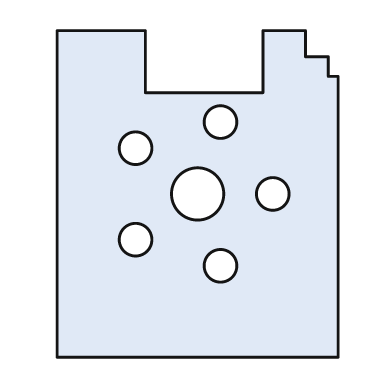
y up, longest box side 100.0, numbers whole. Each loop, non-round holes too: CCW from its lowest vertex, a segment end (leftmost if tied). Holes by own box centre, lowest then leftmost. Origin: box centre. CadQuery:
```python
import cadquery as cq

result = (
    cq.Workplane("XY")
    .moveTo(-43.0, -50.0)
    .lineTo(43.0, -50.0)
    .lineTo(43.0, 36.0)
    .lineTo(40.0, 36.0)
    .lineTo(40.0, 42.0)
    .lineTo(33.0, 42.0)
    .lineTo(33.0, 50.0)
    .lineTo(20.0, 50.0)
    .lineTo(20.0, 31.0)
    .lineTo(-16.0, 31.0)
    .lineTo(-16.0, 50.0)
    .lineTo(-43.0, 50.0)
    .close()
    .moveTo(7.0, -22.0)
    .circle(5.0)
    .moveTo(-19.0, -14.0)
    .circle(5.0)
    .moveTo(0.0, 0.0)
    .circle(8.0)
    .moveTo(23.0, 0.0)
    .circle(5.0)
    .moveTo(-19.0, 14.0)
    .circle(5.0)
    .moveTo(7.0, 22.0)
    .circle(5.0)
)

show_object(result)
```